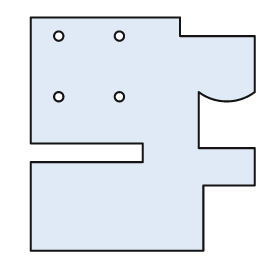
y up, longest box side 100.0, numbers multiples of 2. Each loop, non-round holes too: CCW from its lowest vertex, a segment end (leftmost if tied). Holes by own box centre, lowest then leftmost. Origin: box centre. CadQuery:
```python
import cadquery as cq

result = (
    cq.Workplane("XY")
    .moveTo(-48.0, -50.0)
    .lineTo(26.0, -50.0)
    .lineTo(26.0, -22.0)
    .lineTo(48.0, -22.0)
    .lineTo(48.0, -6.0)
    .lineTo(24.0, -6.0)
    .lineTo(24.0, 18.0)
    .threePointArc((36.0, 14.0), (48.0, 18.0))
    .lineTo(48.0, 42.0)
    .lineTo(16.0, 42.0)
    .lineTo(16.0, 50.0)
    .lineTo(-48.0, 50.0)
    .lineTo(-48.0, -4.0)
    .lineTo(0.0, -4.0)
    .lineTo(0.0, -12.0)
    .lineTo(-48.0, -12.0)
    .close()
    .moveTo(-36.0, 16.0)
    .circle(2.0)
    .moveTo(-10.0, 16.0)
    .circle(2.0)
    .moveTo(-36.0, 42.0)
    .circle(2.0)
    .moveTo(-10.0, 42.0)
    .circle(2.0)
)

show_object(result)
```